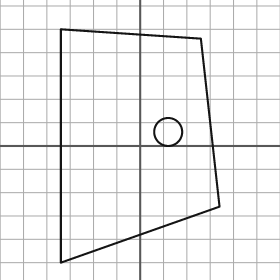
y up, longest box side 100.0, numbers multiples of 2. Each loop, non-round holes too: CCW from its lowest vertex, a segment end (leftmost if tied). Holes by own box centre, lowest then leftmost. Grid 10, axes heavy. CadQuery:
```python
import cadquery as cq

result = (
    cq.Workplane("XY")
    .moveTo(-34.0, -50.0)
    .lineTo(34.0, -26.0)
    .lineTo(26.0, 46.0)
    .lineTo(-34.0, 50.0)
    .close()
    .moveTo(12.0, 6.0)
    .circle(6.0)
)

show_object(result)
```